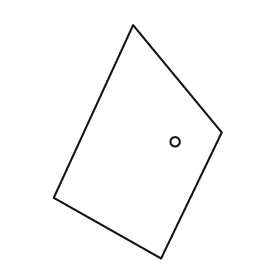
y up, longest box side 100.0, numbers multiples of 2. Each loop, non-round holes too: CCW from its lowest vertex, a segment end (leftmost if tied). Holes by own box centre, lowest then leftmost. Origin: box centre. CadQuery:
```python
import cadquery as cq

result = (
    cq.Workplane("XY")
    .moveTo(10.0, -50.0)
    .lineTo(36.0, 4.0)
    .lineTo(-2.0, 50.0)
    .lineTo(-36.0, -24.0)
    .close()
    .moveTo(16.0, 0.0)
    .circle(2.0)
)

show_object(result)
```